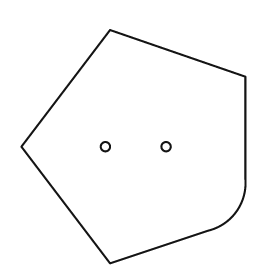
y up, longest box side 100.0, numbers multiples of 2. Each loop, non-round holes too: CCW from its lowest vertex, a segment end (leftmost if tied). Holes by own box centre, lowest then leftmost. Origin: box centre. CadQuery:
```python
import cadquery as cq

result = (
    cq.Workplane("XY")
    .moveTo(-10.0, -50.0)
    .lineTo(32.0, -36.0)
    .threePointArc((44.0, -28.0), (48.0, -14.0))
    .lineTo(48.0, 30.0)
    .lineTo(-10.0, 50.0)
    .lineTo(-48.0, 0.0)
    .close()
    .moveTo(-12.0, 0.0)
    .circle(2.0)
    .moveTo(14.0, 0.0)
    .circle(2.0)
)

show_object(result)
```